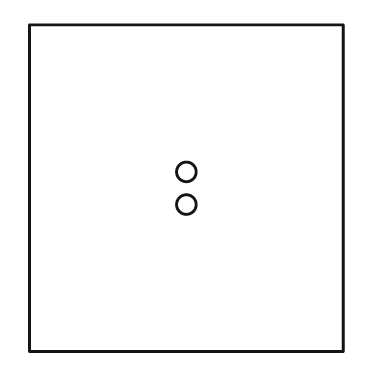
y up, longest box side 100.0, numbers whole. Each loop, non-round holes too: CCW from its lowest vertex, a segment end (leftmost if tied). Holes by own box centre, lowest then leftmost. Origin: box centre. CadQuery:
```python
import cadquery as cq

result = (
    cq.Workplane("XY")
    .moveTo(-48.0, -50.0)
    .lineTo(48.0, -50.0)
    .lineTo(48.0, 50.0)
    .lineTo(-48.0, 50.0)
    .close()
    .moveTo(0.0, -5.0)
    .circle(3.0)
    .moveTo(0.0, 5.0)
    .circle(3.0)
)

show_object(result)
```